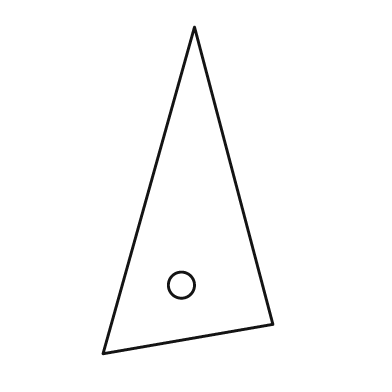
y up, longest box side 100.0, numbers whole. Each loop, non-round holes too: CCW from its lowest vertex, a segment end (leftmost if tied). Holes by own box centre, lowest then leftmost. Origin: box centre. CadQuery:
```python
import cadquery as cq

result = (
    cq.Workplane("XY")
    .moveTo(-26.0, -50.0)
    .lineTo(26.0, -41.0)
    .lineTo(2.0, 50.0)
    .close()
    .moveTo(-2.0, -29.0)
    .circle(4.0)
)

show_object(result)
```